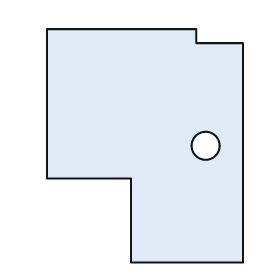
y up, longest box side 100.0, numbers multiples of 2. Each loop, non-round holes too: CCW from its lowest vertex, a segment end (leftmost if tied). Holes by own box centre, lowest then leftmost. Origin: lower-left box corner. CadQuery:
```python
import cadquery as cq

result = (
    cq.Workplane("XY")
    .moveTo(36.0, 0.0)
    .lineTo(84.0, 0.0)
    .lineTo(84.0, 94.0)
    .lineTo(64.0, 94.0)
    .lineTo(64.0, 100.0)
    .lineTo(0.0, 100.0)
    .lineTo(0.0, 36.0)
    .lineTo(36.0, 36.0)
    .close()
    .moveTo(68.0, 50.0)
    .circle(6.0)
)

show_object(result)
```